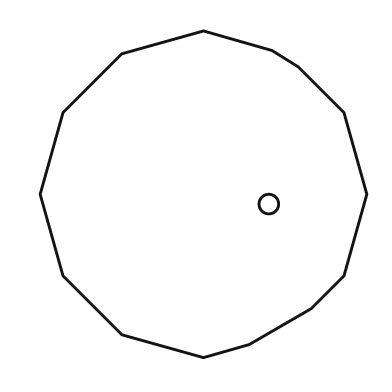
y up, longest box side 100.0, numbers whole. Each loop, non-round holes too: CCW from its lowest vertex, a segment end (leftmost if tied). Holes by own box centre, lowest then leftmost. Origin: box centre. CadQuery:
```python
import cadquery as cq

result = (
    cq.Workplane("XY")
    .moveTo(0.0, -50.0)
    .lineTo(14.0, -46.0)
    .lineTo(33.0, -35.0)
    .lineTo(43.0, -25.0)
    .lineTo(50.0, 0.0)
    .lineTo(43.0, 25.0)
    .lineTo(29.0, 39.0)
    .lineTo(21.0, 44.0)
    .lineTo(0.0, 50.0)
    .lineTo(-25.0, 43.0)
    .lineTo(-43.0, 25.0)
    .lineTo(-50.0, 0.0)
    .lineTo(-43.0, -25.0)
    .lineTo(-25.0, -43.0)
    .close()
    .moveTo(20.0, -3.0)
    .circle(3.0)
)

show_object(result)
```